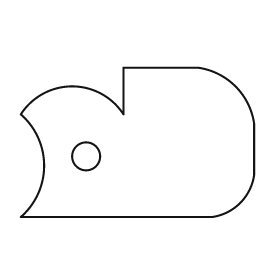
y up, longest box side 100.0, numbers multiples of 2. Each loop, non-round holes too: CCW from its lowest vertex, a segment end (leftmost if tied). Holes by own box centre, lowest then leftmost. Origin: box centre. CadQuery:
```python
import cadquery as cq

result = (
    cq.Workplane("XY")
    .moveTo(-50.0, -32.0)
    .lineTo(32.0, -32.0)
    .threePointArc((44.0, -26.0), (50.0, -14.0))
    .lineTo(50.0, 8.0)
    .threePointArc((42.0, 24.0), (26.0, 32.0))
    .lineTo(-6.0, 32.0)
    .lineTo(-6.0, 12.0)
    .threePointArc((-28.0, 24.0), (-50.0, 12.0))
    .threePointArc((-40.0, -10.0), (-50.0, -32.0))
    .close()
    .moveTo(-22.0, -6.0)
    .circle(6.0)
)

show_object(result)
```